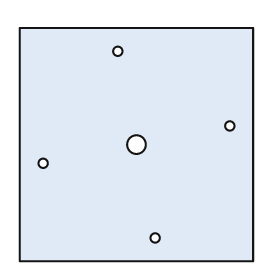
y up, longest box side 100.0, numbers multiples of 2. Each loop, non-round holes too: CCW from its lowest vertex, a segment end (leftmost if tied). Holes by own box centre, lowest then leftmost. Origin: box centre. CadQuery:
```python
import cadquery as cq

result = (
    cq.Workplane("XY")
    .moveTo(-50.0, -50.0)
    .lineTo(50.0, -50.0)
    .lineTo(50.0, 50.0)
    .lineTo(-50.0, 50.0)
    .close()
    .moveTo(8.0, -40.0)
    .circle(2.0)
    .moveTo(-40.0, -8.0)
    .circle(2.0)
    .moveTo(0.0, 0.0)
    .circle(4.0)
    .moveTo(40.0, 8.0)
    .circle(2.0)
    .moveTo(-8.0, 40.0)
    .circle(2.0)
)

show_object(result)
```